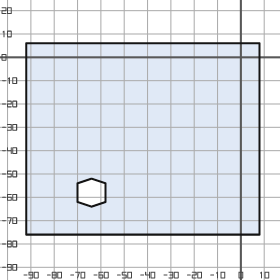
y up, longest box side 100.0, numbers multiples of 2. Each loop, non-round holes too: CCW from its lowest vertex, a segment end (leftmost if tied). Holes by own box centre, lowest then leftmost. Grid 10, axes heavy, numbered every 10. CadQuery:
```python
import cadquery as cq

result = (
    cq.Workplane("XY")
    .moveTo(-92.0, -76.0)
    .lineTo(8.0, -76.0)
    .lineTo(8.0, 6.0)
    .lineTo(-92.0, 6.0)
    .close()
    .moveTo(-64.0, -64.0)
    .lineTo(-58.0, -62.0)
    .lineTo(-58.0, -54.0)
    .lineTo(-64.0, -52.0)
    .lineTo(-70.0, -54.0)
    .lineTo(-70.0, -62.0)
    .close()
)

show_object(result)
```